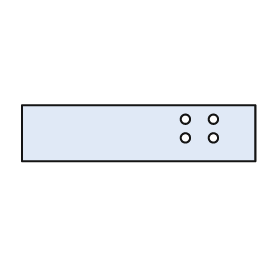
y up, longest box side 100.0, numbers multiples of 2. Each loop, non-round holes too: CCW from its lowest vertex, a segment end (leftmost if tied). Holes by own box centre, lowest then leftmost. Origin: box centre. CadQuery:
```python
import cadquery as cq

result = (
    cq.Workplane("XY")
    .moveTo(-50.0, -12.0)
    .lineTo(50.0, -12.0)
    .lineTo(50.0, 12.0)
    .lineTo(-50.0, 12.0)
    .close()
    .moveTo(20.0, -2.0)
    .circle(2.0)
    .moveTo(32.0, -2.0)
    .circle(2.0)
    .moveTo(20.0, 6.0)
    .circle(2.0)
    .moveTo(32.0, 6.0)
    .circle(2.0)
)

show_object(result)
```